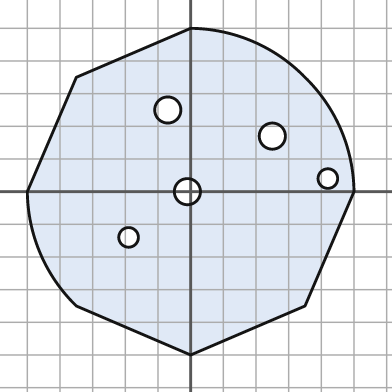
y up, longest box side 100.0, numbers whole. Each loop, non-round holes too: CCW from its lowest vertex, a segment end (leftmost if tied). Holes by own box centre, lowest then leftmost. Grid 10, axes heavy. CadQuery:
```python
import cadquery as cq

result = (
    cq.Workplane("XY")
    .moveTo(0.0, -50.0)
    .lineTo(35.0, -35.0)
    .lineTo(50.0, 0.0)
    .threePointArc((46.0, 19.0), (35.0, 35.0))
    .threePointArc((19.0, 46.0), (0.0, 50.0))
    .lineTo(-35.0, 35.0)
    .lineTo(-50.0, 0.0)
    .threePointArc((-46.0, -19.0), (-35.0, -35.0))
    .close()
    .moveTo(-19.0, -14.0)
    .circle(3.0)
    .moveTo(-1.0, 0.0)
    .circle(4.0)
    .moveTo(42.0, 4.0)
    .circle(3.0)
    .moveTo(25.0, 17.0)
    .circle(4.0)
    .moveTo(-7.0, 25.0)
    .circle(4.0)
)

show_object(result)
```